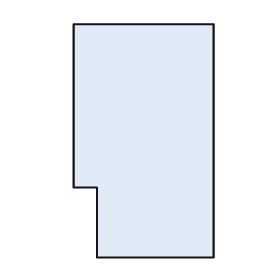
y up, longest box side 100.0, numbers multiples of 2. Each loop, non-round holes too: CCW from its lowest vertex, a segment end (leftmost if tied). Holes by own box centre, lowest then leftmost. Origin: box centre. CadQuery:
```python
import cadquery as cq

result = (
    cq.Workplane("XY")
    .moveTo(-20.0, -50.0)
    .lineTo(30.0, -50.0)
    .lineTo(30.0, 50.0)
    .lineTo(-30.0, 50.0)
    .lineTo(-30.0, -20.0)
    .lineTo(-20.0, -20.0)
    .close()
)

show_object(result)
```